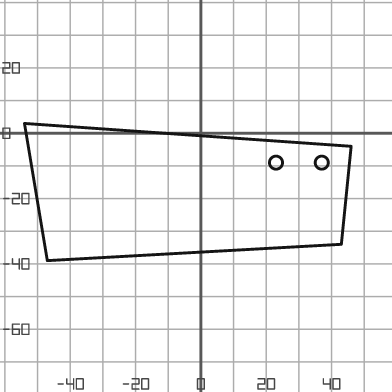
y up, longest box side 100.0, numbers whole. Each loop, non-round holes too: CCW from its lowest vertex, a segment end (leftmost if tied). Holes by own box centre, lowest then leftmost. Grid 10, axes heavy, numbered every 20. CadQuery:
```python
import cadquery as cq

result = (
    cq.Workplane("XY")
    .moveTo(-47.0, -39.0)
    .lineTo(43.0, -34.0)
    .lineTo(46.0, -4.0)
    .lineTo(-54.0, 3.0)
    .close()
    .moveTo(23.0, -9.0)
    .circle(2.0)
    .moveTo(37.0, -9.0)
    .circle(2.0)
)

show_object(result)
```